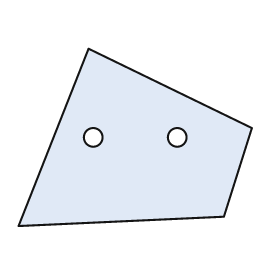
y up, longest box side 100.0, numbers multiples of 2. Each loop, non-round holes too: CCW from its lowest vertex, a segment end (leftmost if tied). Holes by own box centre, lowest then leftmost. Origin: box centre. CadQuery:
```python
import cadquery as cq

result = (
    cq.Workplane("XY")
    .moveTo(-50.0, -38.0)
    .lineTo(38.0, -34.0)
    .lineTo(50.0, 4.0)
    .lineTo(-20.0, 38.0)
    .close()
    .moveTo(-18.0, 0.0)
    .circle(4.0)
    .moveTo(18.0, 0.0)
    .circle(4.0)
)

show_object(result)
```